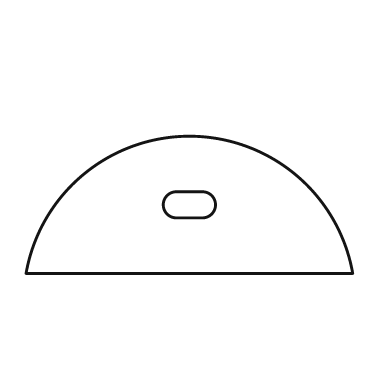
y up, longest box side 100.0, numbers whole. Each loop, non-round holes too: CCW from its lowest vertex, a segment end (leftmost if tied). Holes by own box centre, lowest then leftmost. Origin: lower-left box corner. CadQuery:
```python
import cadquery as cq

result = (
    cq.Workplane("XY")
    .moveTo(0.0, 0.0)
    .lineTo(100.0, 0.0)
    .threePointArc((50.0, 42.0), (0.0, 0.0))
    .close()
    .moveTo(46.0, 17.0)
    .lineTo(54.0, 17.0)
    .threePointArc((58.0, 21.0), (54.0, 25.0))
    .lineTo(46.0, 25.0)
    .threePointArc((42.0, 21.0), (46.0, 17.0))
    .close()
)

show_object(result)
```